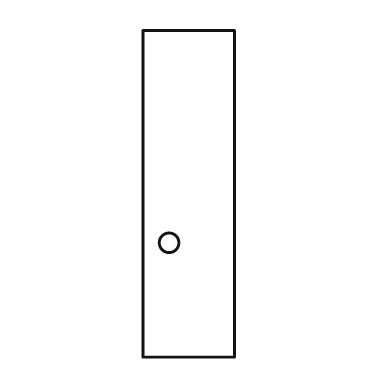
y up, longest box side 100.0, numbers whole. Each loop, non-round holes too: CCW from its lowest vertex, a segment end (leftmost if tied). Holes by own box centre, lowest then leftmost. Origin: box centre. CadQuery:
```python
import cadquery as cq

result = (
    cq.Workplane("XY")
    .moveTo(-14.0, -50.0)
    .lineTo(14.0, -50.0)
    .lineTo(14.0, 50.0)
    .lineTo(-14.0, 50.0)
    .close()
    .moveTo(-6.0, -15.0)
    .circle(3.0)
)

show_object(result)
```